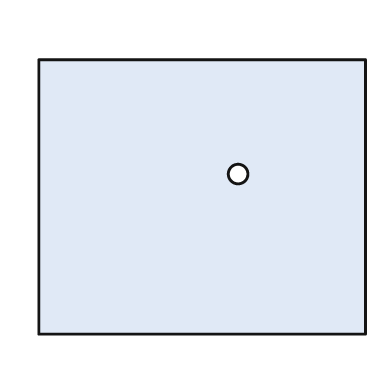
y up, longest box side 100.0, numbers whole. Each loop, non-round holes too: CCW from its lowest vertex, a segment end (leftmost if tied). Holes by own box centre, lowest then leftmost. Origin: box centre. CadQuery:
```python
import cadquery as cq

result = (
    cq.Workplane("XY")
    .moveTo(-50.0, -42.0)
    .lineTo(50.0, -42.0)
    .lineTo(50.0, 42.0)
    .lineTo(-50.0, 42.0)
    .close()
    .moveTo(11.0, 7.0)
    .circle(3.0)
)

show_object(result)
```